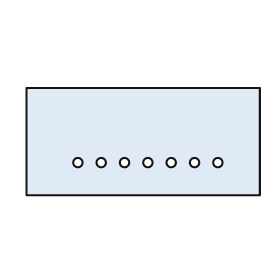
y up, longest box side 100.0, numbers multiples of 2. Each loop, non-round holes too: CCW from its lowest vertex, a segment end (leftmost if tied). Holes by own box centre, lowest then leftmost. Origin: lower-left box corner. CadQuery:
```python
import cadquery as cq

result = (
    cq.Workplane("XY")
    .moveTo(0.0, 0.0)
    .lineTo(100.0, 0.0)
    .lineTo(100.0, 46.0)
    .lineTo(0.0, 46.0)
    .close()
    .moveTo(22.0, 14.0)
    .circle(2.0)
    .moveTo(32.0, 14.0)
    .circle(2.0)
    .moveTo(42.0, 14.0)
    .circle(2.0)
    .moveTo(52.0, 14.0)
    .circle(2.0)
    .moveTo(62.0, 14.0)
    .circle(2.0)
    .moveTo(72.0, 14.0)
    .circle(2.0)
    .moveTo(82.0, 14.0)
    .circle(2.0)
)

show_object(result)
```